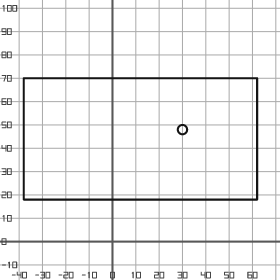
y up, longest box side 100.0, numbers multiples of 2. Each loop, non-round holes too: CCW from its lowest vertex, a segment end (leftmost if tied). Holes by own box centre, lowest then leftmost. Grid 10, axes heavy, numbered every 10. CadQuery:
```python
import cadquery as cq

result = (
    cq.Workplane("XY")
    .moveTo(-38.0, 18.0)
    .lineTo(62.0, 18.0)
    .lineTo(62.0, 70.0)
    .lineTo(-38.0, 70.0)
    .close()
    .moveTo(30.0, 48.0)
    .circle(2.0)
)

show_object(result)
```